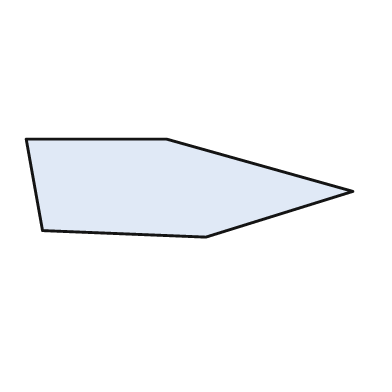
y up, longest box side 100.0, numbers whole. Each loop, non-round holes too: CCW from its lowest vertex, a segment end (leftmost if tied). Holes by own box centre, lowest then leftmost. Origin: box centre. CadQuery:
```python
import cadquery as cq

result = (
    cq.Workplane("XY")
    .moveTo(5.0, -15.0)
    .lineTo(50.0, -1.0)
    .lineTo(-7.0, 15.0)
    .lineTo(-50.0, 15.0)
    .lineTo(-45.0, -13.0)
    .close()
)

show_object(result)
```